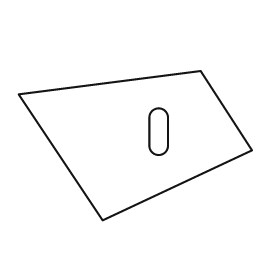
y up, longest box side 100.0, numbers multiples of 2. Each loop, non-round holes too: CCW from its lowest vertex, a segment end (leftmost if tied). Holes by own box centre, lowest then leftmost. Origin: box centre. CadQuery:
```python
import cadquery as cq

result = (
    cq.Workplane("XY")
    .moveTo(-14.0, -32.0)
    .lineTo(50.0, -2.0)
    .lineTo(28.0, 32.0)
    .lineTo(-50.0, 22.0)
    .close()
    .moveTo(6.0, 0.0)
    .threePointArc((10.0, -4.0), (14.0, 0.0))
    .lineTo(14.0, 12.0)
    .threePointArc((10.0, 16.0), (6.0, 12.0))
    .close()
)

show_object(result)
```